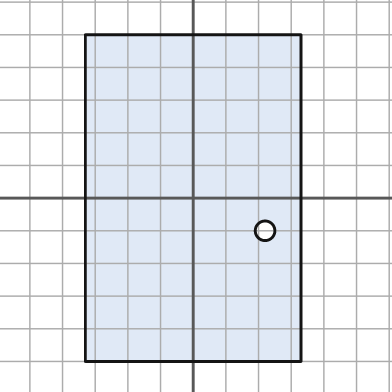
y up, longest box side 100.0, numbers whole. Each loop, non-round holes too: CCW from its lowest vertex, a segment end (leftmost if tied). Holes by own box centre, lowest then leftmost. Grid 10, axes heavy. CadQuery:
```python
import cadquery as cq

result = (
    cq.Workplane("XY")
    .moveTo(-33.0, -50.0)
    .lineTo(33.0, -50.0)
    .lineTo(33.0, 50.0)
    .lineTo(-33.0, 50.0)
    .close()
    .moveTo(22.0, -10.0)
    .circle(3.0)
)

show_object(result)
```